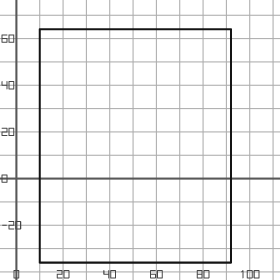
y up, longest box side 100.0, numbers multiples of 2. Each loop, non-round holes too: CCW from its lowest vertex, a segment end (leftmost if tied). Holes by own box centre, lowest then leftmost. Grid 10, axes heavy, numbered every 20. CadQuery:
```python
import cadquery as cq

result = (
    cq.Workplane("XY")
    .moveTo(10.0, -36.0)
    .lineTo(92.0, -36.0)
    .lineTo(92.0, 64.0)
    .lineTo(10.0, 64.0)
    .close()
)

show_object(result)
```